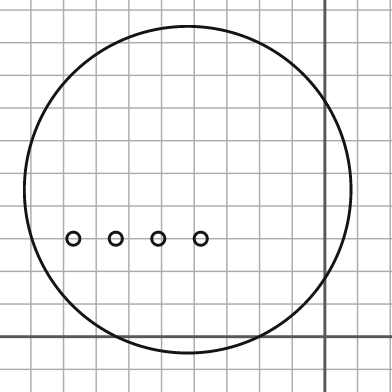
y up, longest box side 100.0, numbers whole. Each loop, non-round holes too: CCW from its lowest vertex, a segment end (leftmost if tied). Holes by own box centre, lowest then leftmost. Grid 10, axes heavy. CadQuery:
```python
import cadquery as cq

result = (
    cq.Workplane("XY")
    .moveTo(-42.0, 45.0)
    .circle(50.0)
    .moveTo(-77.0, 30.0)
    .circle(2.0)
    .moveTo(-64.0, 30.0)
    .circle(2.0)
    .moveTo(-51.0, 30.0)
    .circle(2.0)
    .moveTo(-38.0, 30.0)
    .circle(2.0)
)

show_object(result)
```